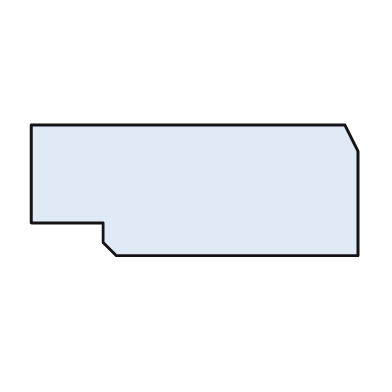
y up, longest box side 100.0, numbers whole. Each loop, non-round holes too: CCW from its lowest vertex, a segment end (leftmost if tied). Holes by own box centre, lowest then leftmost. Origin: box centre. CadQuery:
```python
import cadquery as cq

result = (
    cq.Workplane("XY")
    .moveTo(-24.0, -20.0)
    .lineTo(50.0, -20.0)
    .lineTo(50.0, 12.0)
    .lineTo(46.0, 20.0)
    .lineTo(-50.0, 20.0)
    .lineTo(-50.0, -10.0)
    .lineTo(-28.0, -10.0)
    .lineTo(-28.0, -16.0)
    .close()
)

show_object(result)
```